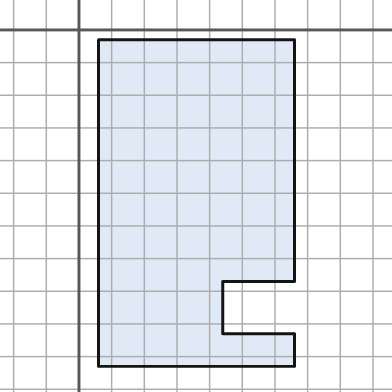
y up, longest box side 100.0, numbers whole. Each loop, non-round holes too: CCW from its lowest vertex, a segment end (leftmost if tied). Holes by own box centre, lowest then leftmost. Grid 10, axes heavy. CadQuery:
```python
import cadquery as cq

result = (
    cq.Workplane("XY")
    .moveTo(6.0, -103.0)
    .lineTo(66.0, -103.0)
    .lineTo(66.0, -93.0)
    .lineTo(44.0, -93.0)
    .lineTo(44.0, -77.0)
    .lineTo(66.0, -77.0)
    .lineTo(66.0, -3.0)
    .lineTo(6.0, -3.0)
    .close()
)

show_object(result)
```